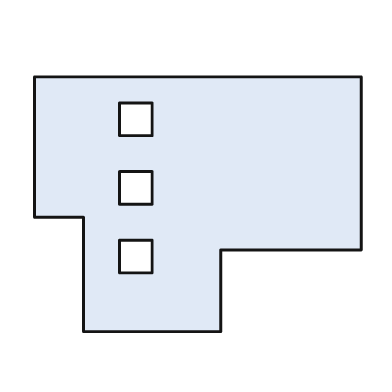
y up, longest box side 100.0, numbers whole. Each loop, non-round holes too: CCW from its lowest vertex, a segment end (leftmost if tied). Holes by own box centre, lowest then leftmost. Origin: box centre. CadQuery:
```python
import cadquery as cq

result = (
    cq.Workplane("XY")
    .moveTo(-35.0, -39.0)
    .lineTo(7.0, -39.0)
    .lineTo(7.0, -14.0)
    .lineTo(50.0, -14.0)
    .lineTo(50.0, 39.0)
    .lineTo(-50.0, 39.0)
    .lineTo(-50.0, -4.0)
    .lineTo(-35.0, -4.0)
    .close()
    .moveTo(-24.0, -21.0)
    .lineTo(-14.0, -21.0)
    .lineTo(-14.0, -11.0)
    .lineTo(-24.0, -11.0)
    .close()
    .moveTo(-24.0, 0.0)
    .lineTo(-14.0, 0.0)
    .lineTo(-14.0, 10.0)
    .lineTo(-24.0, 10.0)
    .close()
    .moveTo(-24.0, 21.0)
    .lineTo(-14.0, 21.0)
    .lineTo(-14.0, 31.0)
    .lineTo(-24.0, 31.0)
    .close()
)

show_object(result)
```